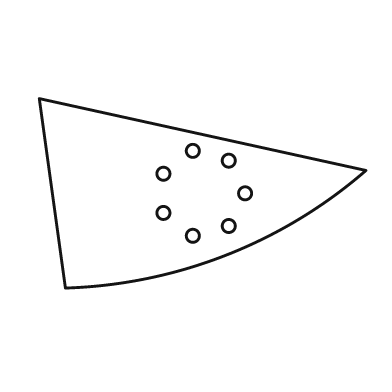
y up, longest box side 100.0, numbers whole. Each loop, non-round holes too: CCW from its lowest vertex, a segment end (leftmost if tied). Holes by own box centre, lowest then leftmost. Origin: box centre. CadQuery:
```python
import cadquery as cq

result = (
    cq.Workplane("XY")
    .moveTo(-42.0, -29.0)
    .threePointArc((7.0, -19.0), (50.0, 7.0))
    .lineTo(-50.0, 29.0)
    .close()
    .moveTo(-3.0, -13.0)
    .circle(2.0)
    .moveTo(8.0, -10.0)
    .circle(2.0)
    .moveTo(-12.0, -6.0)
    .circle(2.0)
    .moveTo(13.0, 0.0)
    .circle(2.0)
    .moveTo(-12.0, 6.0)
    .circle(2.0)
    .moveTo(8.0, 10.0)
    .circle(2.0)
    .moveTo(-3.0, 13.0)
    .circle(2.0)
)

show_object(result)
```